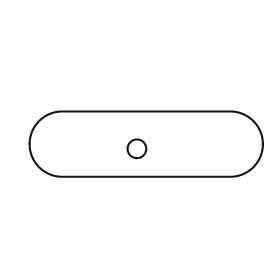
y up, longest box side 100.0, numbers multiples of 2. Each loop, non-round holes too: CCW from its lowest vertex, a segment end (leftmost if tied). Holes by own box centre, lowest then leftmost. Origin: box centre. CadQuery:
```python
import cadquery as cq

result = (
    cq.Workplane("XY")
    .moveTo(-36.0, -14.0)
    .lineTo(36.0, -14.0)
    .threePointArc((50.0, 0.0), (36.0, 14.0))
    .lineTo(-36.0, 14.0)
    .threePointArc((-50.0, 0.0), (-36.0, -14.0))
    .close()
    .moveTo(-4.0, -2.0)
    .circle(4.0)
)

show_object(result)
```